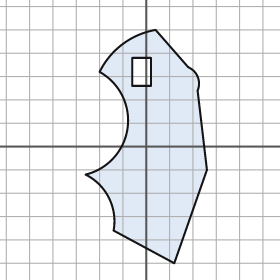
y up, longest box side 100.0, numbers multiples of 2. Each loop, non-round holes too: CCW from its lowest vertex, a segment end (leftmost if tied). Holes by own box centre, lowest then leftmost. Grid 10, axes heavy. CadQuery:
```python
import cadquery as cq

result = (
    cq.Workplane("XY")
    .moveTo(12.0, -50.0)
    .lineTo(26.0, -10.0)
    .lineTo(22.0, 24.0)
    .threePointArc((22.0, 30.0), (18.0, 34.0))
    .lineTo(4.0, 50.0)
    .threePointArc((-10.0, 44.0), (-20.0, 32.0))
    .threePointArc((-8.0, 8.0), (-26.0, -12.0))
    .threePointArc((-16.0, -22.0), (-14.0, -36.0))
    .close()
    .moveTo(-6.0, 26.0)
    .lineTo(2.0, 26.0)
    .lineTo(2.0, 38.0)
    .lineTo(-6.0, 38.0)
    .close()
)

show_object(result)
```